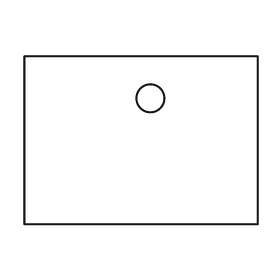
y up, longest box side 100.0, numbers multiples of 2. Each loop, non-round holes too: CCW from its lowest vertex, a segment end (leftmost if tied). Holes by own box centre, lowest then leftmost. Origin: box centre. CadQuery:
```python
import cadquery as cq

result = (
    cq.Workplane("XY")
    .moveTo(-50.0, -36.0)
    .lineTo(50.0, -36.0)
    .lineTo(50.0, 36.0)
    .lineTo(-50.0, 36.0)
    .close()
    .moveTo(4.0, 18.0)
    .circle(6.0)
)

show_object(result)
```